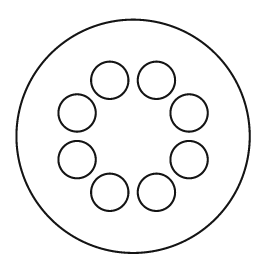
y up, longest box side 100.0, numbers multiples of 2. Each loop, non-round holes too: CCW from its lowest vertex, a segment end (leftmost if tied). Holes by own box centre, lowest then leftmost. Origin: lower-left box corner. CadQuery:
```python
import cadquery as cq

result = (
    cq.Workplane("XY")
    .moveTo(50.0, 50.0)
    .circle(50.0)
    .moveTo(40.0, 26.0)
    .circle(8.0)
    .moveTo(60.0, 26.0)
    .circle(8.0)
    .moveTo(26.0, 40.0)
    .circle(8.0)
    .moveTo(74.0, 40.0)
    .circle(8.0)
    .moveTo(26.0, 60.0)
    .circle(8.0)
    .moveTo(74.0, 60.0)
    .circle(8.0)
    .moveTo(40.0, 74.0)
    .circle(8.0)
    .moveTo(60.0, 74.0)
    .circle(8.0)
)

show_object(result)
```